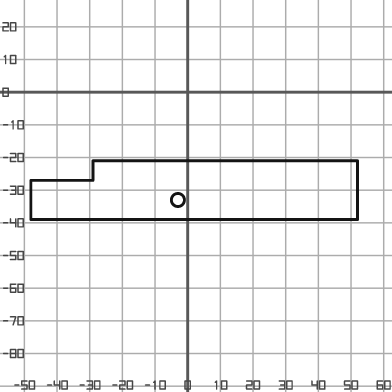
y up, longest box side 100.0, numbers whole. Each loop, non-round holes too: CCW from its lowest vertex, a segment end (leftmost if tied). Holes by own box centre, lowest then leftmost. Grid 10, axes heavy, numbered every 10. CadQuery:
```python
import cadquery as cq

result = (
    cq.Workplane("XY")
    .moveTo(-48.0, -39.0)
    .lineTo(52.0, -39.0)
    .lineTo(52.0, -21.0)
    .lineTo(-29.0, -21.0)
    .lineTo(-29.0, -27.0)
    .lineTo(-48.0, -27.0)
    .close()
    .moveTo(-3.0, -33.0)
    .circle(2.0)
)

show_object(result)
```